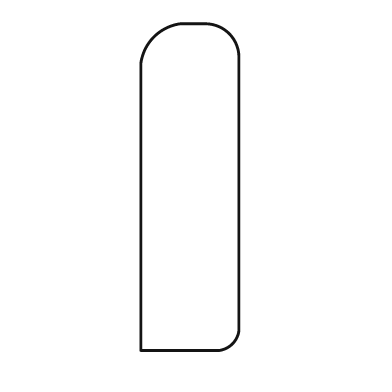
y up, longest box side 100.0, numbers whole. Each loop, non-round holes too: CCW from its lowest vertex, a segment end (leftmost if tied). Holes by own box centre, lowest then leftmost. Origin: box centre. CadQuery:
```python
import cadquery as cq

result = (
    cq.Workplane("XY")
    .moveTo(-15.0, -50.0)
    .lineTo(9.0, -50.0)
    .threePointArc((13.0, -48.0), (15.0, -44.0))
    .lineTo(15.0, 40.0)
    .threePointArc((12.0, 47.0), (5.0, 50.0))
    .lineTo(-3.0, 50.0)
    .threePointArc((-11.0, 46.0), (-15.0, 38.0))
    .close()
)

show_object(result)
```